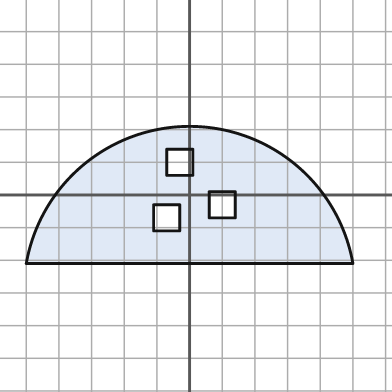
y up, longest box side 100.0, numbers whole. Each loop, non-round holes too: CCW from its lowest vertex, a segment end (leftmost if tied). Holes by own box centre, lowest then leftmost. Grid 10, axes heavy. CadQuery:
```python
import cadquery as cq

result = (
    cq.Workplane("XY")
    .moveTo(-50.0, -21.0)
    .lineTo(50.0, -21.0)
    .threePointArc((0.0, 21.0), (-50.0, -21.0))
    .close()
    .moveTo(-11.0, -11.0)
    .lineTo(-3.0, -11.0)
    .lineTo(-3.0, -3.0)
    .lineTo(-11.0, -3.0)
    .close()
    .moveTo(6.0, -7.0)
    .lineTo(14.0, -7.0)
    .lineTo(14.0, 1.0)
    .lineTo(6.0, 1.0)
    .close()
    .moveTo(-7.0, 6.0)
    .lineTo(1.0, 6.0)
    .lineTo(1.0, 14.0)
    .lineTo(-7.0, 14.0)
    .close()
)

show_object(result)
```